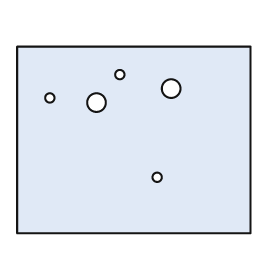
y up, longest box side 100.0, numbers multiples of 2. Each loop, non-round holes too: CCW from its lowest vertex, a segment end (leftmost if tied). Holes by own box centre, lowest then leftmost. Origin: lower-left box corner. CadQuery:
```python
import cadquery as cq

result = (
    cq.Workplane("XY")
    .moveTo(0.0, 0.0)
    .lineTo(100.0, 0.0)
    .lineTo(100.0, 80.0)
    .lineTo(0.0, 80.0)
    .close()
    .moveTo(60.0, 24.0)
    .circle(2.0)
    .moveTo(34.0, 56.0)
    .circle(4.0)
    .moveTo(14.0, 58.0)
    .circle(2.0)
    .moveTo(66.0, 62.0)
    .circle(4.0)
    .moveTo(44.0, 68.0)
    .circle(2.0)
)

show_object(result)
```